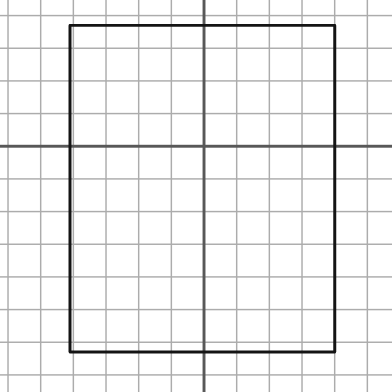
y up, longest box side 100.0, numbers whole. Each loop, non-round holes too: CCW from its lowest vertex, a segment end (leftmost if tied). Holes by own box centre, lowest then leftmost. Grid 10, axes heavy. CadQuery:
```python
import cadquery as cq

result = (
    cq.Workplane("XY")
    .moveTo(-41.0, -63.0)
    .lineTo(40.0, -63.0)
    .lineTo(40.0, 37.0)
    .lineTo(-41.0, 37.0)
    .close()
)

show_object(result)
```